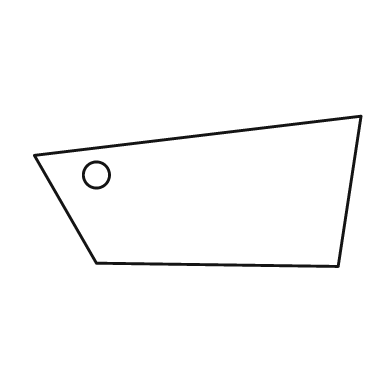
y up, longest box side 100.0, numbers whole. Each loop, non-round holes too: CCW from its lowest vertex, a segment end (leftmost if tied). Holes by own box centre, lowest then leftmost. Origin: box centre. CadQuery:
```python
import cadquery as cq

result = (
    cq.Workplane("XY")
    .moveTo(43.0, -23.0)
    .lineTo(50.0, 23.0)
    .lineTo(-50.0, 11.0)
    .lineTo(-31.0, -22.0)
    .close()
    .moveTo(-31.0, 5.0)
    .circle(4.0)
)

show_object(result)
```